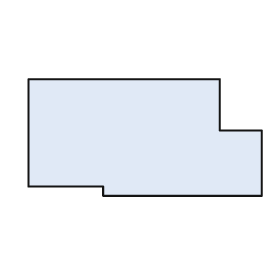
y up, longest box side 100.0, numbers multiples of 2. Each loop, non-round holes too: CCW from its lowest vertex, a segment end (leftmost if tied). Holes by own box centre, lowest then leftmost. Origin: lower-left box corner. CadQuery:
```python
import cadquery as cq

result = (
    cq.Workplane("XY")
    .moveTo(32.0, 0.0)
    .lineTo(100.0, 0.0)
    .lineTo(100.0, 28.0)
    .lineTo(82.0, 28.0)
    .lineTo(82.0, 50.0)
    .lineTo(0.0, 50.0)
    .lineTo(0.0, 4.0)
    .lineTo(32.0, 4.0)
    .close()
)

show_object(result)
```